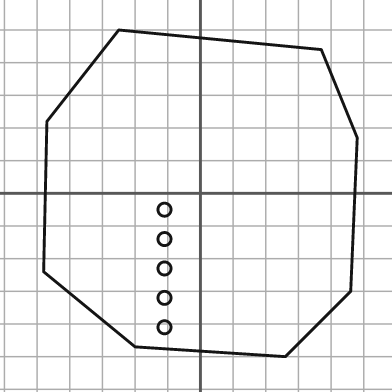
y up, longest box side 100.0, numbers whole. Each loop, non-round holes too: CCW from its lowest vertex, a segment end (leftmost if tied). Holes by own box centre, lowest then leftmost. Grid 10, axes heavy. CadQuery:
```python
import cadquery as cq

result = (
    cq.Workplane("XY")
    .moveTo(26.0, -50.0)
    .lineTo(46.0, -30.0)
    .lineTo(48.0, 17.0)
    .lineTo(37.0, 44.0)
    .lineTo(-25.0, 50.0)
    .lineTo(-47.0, 22.0)
    .lineTo(-48.0, -24.0)
    .lineTo(-20.0, -47.0)
    .close()
    .moveTo(-11.0, -41.0)
    .circle(2.0)
    .moveTo(-11.0, -32.0)
    .circle(2.0)
    .moveTo(-11.0, -23.0)
    .circle(2.0)
    .moveTo(-11.0, -14.0)
    .circle(2.0)
    .moveTo(-11.0, -5.0)
    .circle(2.0)
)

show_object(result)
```